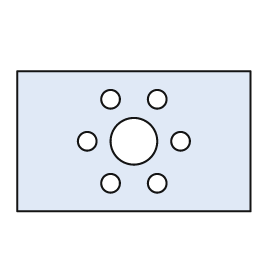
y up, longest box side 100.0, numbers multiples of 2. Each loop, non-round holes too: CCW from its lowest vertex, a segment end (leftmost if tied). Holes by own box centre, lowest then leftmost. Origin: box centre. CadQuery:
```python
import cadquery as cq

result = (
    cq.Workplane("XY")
    .moveTo(-50.0, -30.0)
    .lineTo(50.0, -30.0)
    .lineTo(50.0, 30.0)
    .lineTo(-50.0, 30.0)
    .close()
    .moveTo(-10.0, -18.0)
    .circle(4.0)
    .moveTo(10.0, -18.0)
    .circle(4.0)
    .moveTo(-20.0, 0.0)
    .circle(4.0)
    .moveTo(0.0, 0.0)
    .circle(10.0)
    .moveTo(20.0, 0.0)
    .circle(4.0)
    .moveTo(-10.0, 18.0)
    .circle(4.0)
    .moveTo(10.0, 18.0)
    .circle(4.0)
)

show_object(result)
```